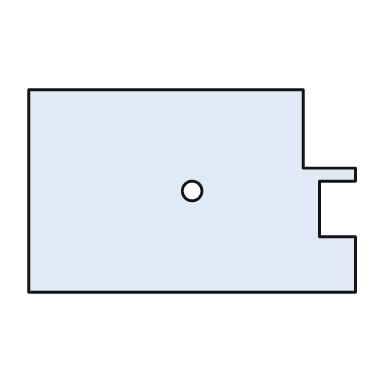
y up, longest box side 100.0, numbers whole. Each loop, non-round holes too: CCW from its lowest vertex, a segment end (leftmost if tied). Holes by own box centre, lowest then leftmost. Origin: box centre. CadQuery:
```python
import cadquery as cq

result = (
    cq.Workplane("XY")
    .moveTo(-50.0, -31.0)
    .lineTo(50.0, -31.0)
    .lineTo(50.0, -14.0)
    .lineTo(39.0, -14.0)
    .lineTo(39.0, 3.0)
    .lineTo(50.0, 3.0)
    .lineTo(50.0, 7.0)
    .lineTo(34.0, 7.0)
    .lineTo(34.0, 31.0)
    .lineTo(-50.0, 31.0)
    .close()
    .moveTo(0.0, 0.0)
    .circle(3.0)
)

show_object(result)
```